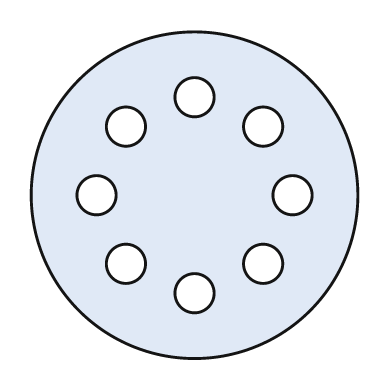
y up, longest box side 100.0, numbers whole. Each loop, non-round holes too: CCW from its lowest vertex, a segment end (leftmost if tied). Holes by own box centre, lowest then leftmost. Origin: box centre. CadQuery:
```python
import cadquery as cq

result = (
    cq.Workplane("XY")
    .moveTo(0.0, 0.0)
    .circle(50.0)
    .moveTo(0.0, -30.0)
    .circle(6.0)
    .moveTo(-21.0, -21.0)
    .circle(6.0)
    .moveTo(21.0, -21.0)
    .circle(6.0)
    .moveTo(-30.0, 0.0)
    .circle(6.0)
    .moveTo(30.0, 0.0)
    .circle(6.0)
    .moveTo(-21.0, 21.0)
    .circle(6.0)
    .moveTo(21.0, 21.0)
    .circle(6.0)
    .moveTo(0.0, 30.0)
    .circle(6.0)
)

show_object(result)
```